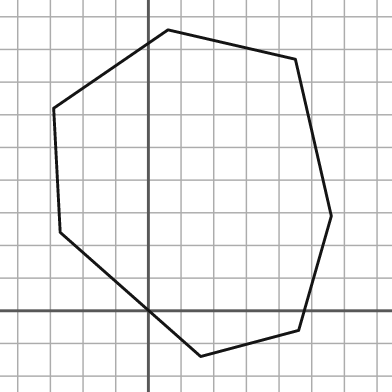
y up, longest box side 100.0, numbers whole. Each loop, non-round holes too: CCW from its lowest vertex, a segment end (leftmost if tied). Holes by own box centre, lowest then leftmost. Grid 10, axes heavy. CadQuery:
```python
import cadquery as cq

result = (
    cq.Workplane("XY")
    .moveTo(16.0, -14.0)
    .lineTo(46.0, -6.0)
    .lineTo(56.0, 29.0)
    .lineTo(45.0, 77.0)
    .lineTo(6.0, 86.0)
    .lineTo(-29.0, 62.0)
    .lineTo(-27.0, 24.0)
    .close()
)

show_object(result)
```